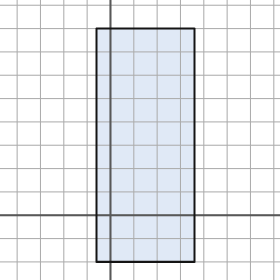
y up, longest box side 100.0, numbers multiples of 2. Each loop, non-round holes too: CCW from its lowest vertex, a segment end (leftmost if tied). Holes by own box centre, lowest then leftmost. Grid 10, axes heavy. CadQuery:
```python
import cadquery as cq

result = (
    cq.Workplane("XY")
    .moveTo(-6.0, -20.0)
    .lineTo(36.0, -20.0)
    .lineTo(36.0, 80.0)
    .lineTo(-6.0, 80.0)
    .close()
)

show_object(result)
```